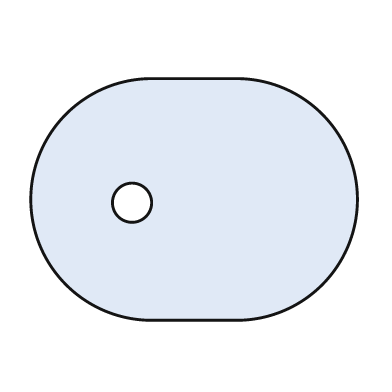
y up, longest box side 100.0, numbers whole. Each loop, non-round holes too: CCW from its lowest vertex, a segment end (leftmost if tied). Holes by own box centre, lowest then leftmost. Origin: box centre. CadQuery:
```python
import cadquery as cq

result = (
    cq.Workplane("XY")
    .moveTo(-13.0, -37.0)
    .lineTo(13.0, -37.0)
    .threePointArc((50.0, 0.0), (13.0, 37.0))
    .lineTo(-13.0, 37.0)
    .threePointArc((-50.0, 0.0), (-13.0, -37.0))
    .close()
    .moveTo(-19.0, -1.0)
    .circle(6.0)
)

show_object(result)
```